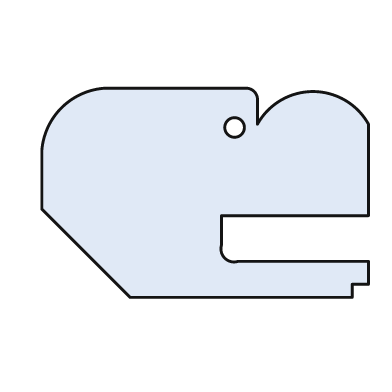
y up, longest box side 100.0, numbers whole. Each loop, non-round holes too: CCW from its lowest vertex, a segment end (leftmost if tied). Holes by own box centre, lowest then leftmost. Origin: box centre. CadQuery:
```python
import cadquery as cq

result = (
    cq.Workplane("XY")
    .moveTo(-23.0, -32.0)
    .lineTo(45.0, -32.0)
    .lineTo(45.0, -28.0)
    .lineTo(50.0, -28.0)
    .lineTo(50.0, -21.0)
    .lineTo(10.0, -21.0)
    .threePointArc((6.0, -20.0), (5.0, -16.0))
    .lineTo(5.0, -7.0)
    .lineTo(50.0, -7.0)
    .lineTo(50.0, 21.0)
    .threePointArc((33.0, 31.0), (16.0, 21.0))
    .lineTo(16.0, 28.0)
    .threePointArc((15.0, 31.0), (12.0, 32.0))
    .lineTo(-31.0, 32.0)
    .threePointArc((-44.0, 26.0), (-50.0, 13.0))
    .lineTo(-50.0, -5.0)
    .close()
    .moveTo(9.0, 20.0)
    .circle(3.0)
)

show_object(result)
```